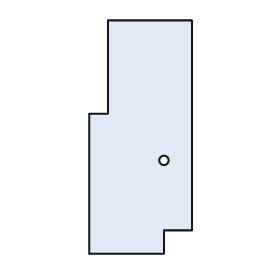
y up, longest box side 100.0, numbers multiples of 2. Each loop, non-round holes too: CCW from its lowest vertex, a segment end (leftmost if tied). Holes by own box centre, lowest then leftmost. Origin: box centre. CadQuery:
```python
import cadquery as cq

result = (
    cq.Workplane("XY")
    .moveTo(-22.0, -50.0)
    .lineTo(10.0, -50.0)
    .lineTo(10.0, -40.0)
    .lineTo(22.0, -40.0)
    .lineTo(22.0, 50.0)
    .lineTo(-14.0, 50.0)
    .lineTo(-14.0, 10.0)
    .lineTo(-22.0, 10.0)
    .close()
    .moveTo(10.0, -10.0)
    .circle(2.0)
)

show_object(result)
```